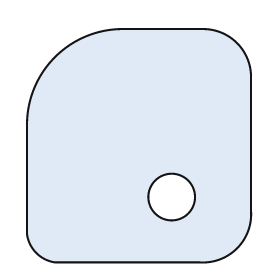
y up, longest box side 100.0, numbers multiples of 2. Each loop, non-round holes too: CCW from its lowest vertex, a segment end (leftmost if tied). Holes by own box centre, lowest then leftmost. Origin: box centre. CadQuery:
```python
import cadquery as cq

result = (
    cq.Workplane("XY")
    .moveTo(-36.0, -50.0)
    .lineTo(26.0, -50.0)
    .threePointArc((42.0, -44.0), (48.0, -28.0))
    .lineTo(48.0, 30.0)
    .threePointArc((42.0, 44.0), (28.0, 50.0))
    .lineTo(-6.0, 50.0)
    .threePointArc((-36.0, 38.0), (-48.0, 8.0))
    .lineTo(-48.0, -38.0)
    .threePointArc((-44.0, -46.0), (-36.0, -50.0))
    .close()
    .moveTo(14.0, -22.0)
    .circle(10.0)
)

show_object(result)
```